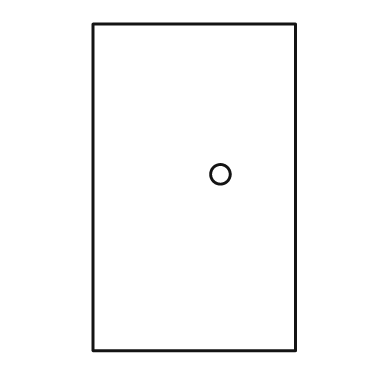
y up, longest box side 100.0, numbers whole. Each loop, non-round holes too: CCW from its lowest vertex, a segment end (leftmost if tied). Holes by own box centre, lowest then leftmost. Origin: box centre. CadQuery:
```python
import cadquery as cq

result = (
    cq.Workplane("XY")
    .moveTo(-31.0, -50.0)
    .lineTo(31.0, -50.0)
    .lineTo(31.0, 50.0)
    .lineTo(-31.0, 50.0)
    .close()
    .moveTo(8.0, 4.0)
    .circle(3.0)
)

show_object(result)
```